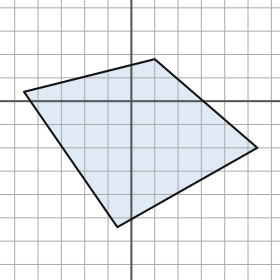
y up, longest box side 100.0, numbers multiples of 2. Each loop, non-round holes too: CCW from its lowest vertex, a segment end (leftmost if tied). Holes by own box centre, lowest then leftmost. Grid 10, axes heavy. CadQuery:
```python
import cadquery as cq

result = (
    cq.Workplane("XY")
    .moveTo(-6.0, -54.0)
    .lineTo(54.0, -20.0)
    .lineTo(10.0, 18.0)
    .lineTo(-46.0, 4.0)
    .close()
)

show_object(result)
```